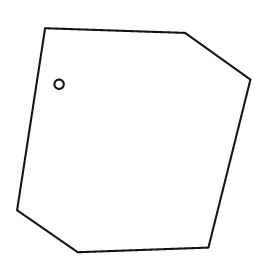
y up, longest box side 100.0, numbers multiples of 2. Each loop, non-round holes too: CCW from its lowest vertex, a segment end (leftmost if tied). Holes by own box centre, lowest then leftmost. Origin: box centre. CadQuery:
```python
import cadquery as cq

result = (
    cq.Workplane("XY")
    .moveTo(-24.0, -48.0)
    .lineTo(32.0, -46.0)
    .lineTo(50.0, 26.0)
    .lineTo(22.0, 46.0)
    .lineTo(-38.0, 48.0)
    .lineTo(-50.0, -30.0)
    .close()
    .moveTo(-32.0, 24.0)
    .circle(2.0)
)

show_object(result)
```